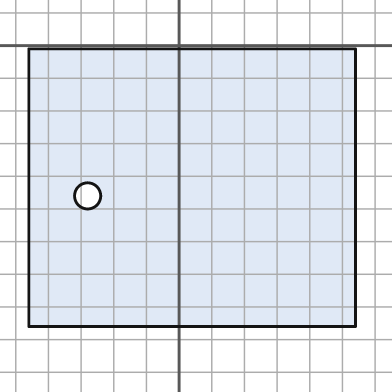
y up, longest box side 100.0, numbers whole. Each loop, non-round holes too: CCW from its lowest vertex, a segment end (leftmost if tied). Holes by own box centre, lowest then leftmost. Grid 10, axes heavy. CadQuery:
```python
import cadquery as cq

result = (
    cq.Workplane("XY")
    .moveTo(-46.0, -86.0)
    .lineTo(54.0, -86.0)
    .lineTo(54.0, -1.0)
    .lineTo(-46.0, -1.0)
    .close()
    .moveTo(-28.0, -46.0)
    .circle(4.0)
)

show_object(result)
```